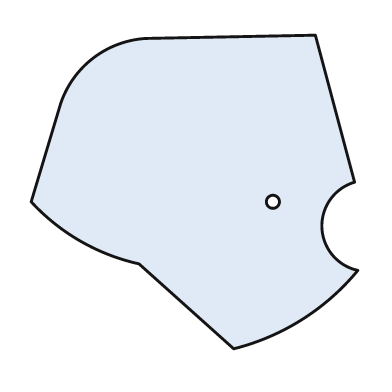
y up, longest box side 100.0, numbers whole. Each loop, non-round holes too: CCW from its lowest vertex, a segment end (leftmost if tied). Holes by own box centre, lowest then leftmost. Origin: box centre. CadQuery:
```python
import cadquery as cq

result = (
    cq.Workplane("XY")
    .moveTo(12.0, -48.0)
    .threePointArc((33.0, -39.0), (50.0, -24.0))
    .threePointArc((39.0, -11.0), (49.0, 3.0))
    .lineTo(37.0, 48.0)
    .lineTo(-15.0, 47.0)
    .threePointArc((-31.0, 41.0), (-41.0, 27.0))
    .lineTo(-50.0, -3.0)
    .threePointArc((-35.0, -15.0), (-17.0, -22.0))
    .close()
    .moveTo(24.0, -3.0)
    .circle(2.0)
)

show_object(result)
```